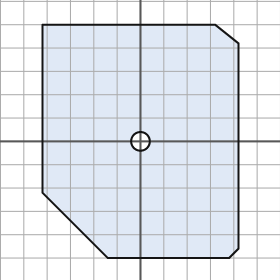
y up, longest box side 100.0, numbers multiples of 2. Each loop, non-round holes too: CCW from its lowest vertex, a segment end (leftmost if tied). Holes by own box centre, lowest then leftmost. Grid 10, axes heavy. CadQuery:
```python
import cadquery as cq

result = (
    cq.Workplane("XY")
    .moveTo(-14.0, -50.0)
    .lineTo(38.0, -50.0)
    .lineTo(42.0, -46.0)
    .lineTo(42.0, 42.0)
    .lineTo(32.0, 50.0)
    .lineTo(-42.0, 50.0)
    .lineTo(-42.0, -22.0)
    .close()
    .moveTo(0.0, 0.0)
    .circle(4.0)
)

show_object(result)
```